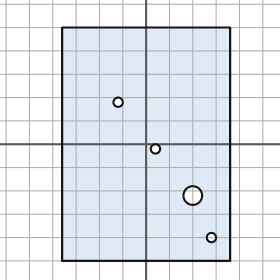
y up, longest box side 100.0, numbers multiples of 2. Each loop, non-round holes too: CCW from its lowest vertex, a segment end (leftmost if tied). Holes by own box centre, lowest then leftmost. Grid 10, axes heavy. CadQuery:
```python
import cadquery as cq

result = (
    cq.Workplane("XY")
    .moveTo(-36.0, -50.0)
    .lineTo(36.0, -50.0)
    .lineTo(36.0, 50.0)
    .lineTo(-36.0, 50.0)
    .close()
    .moveTo(28.0, -40.0)
    .circle(2.0)
    .moveTo(20.0, -22.0)
    .circle(4.0)
    .moveTo(4.0, -2.0)
    .circle(2.0)
    .moveTo(-12.0, 18.0)
    .circle(2.0)
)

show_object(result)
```